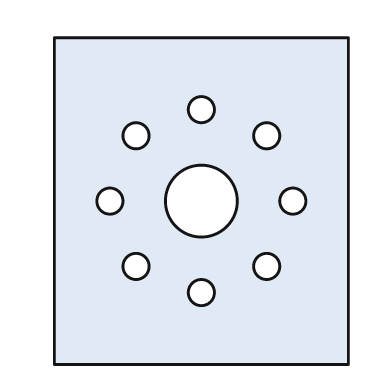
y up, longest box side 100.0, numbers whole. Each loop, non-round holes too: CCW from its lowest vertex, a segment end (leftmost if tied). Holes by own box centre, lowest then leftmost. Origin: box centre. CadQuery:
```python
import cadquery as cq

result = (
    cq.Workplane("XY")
    .moveTo(-45.0, -50.0)
    .lineTo(45.0, -50.0)
    .lineTo(45.0, 50.0)
    .lineTo(-45.0, 50.0)
    .close()
    .moveTo(0.0, -28.0)
    .circle(4.0)
    .moveTo(-20.0, -20.0)
    .circle(4.0)
    .moveTo(20.0, -20.0)
    .circle(4.0)
    .moveTo(-28.0, 0.0)
    .circle(4.0)
    .moveTo(0.0, 0.0)
    .circle(11.0)
    .moveTo(28.0, 0.0)
    .circle(4.0)
    .moveTo(-20.0, 20.0)
    .circle(4.0)
    .moveTo(20.0, 20.0)
    .circle(4.0)
    .moveTo(0.0, 28.0)
    .circle(4.0)
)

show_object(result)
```